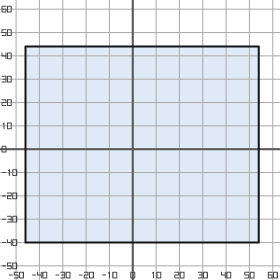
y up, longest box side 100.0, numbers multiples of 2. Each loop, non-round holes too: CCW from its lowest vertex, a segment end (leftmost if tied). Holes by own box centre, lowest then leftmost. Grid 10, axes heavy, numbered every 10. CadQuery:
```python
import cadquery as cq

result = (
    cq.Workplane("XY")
    .moveTo(-46.0, -40.0)
    .lineTo(54.0, -40.0)
    .lineTo(54.0, 44.0)
    .lineTo(-46.0, 44.0)
    .close()
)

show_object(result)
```